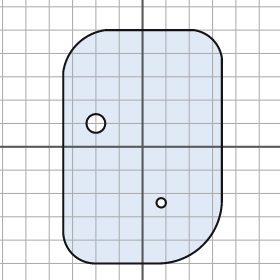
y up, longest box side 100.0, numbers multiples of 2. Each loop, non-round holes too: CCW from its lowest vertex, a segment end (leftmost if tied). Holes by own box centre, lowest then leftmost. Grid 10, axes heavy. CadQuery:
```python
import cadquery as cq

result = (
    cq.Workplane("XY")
    .moveTo(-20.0, -50.0)
    .lineTo(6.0, -50.0)
    .threePointArc((26.0, -42.0), (34.0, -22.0))
    .lineTo(34.0, 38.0)
    .threePointArc((30.0, 46.0), (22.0, 50.0))
    .lineTo(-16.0, 50.0)
    .threePointArc((-28.0, 44.0), (-34.0, 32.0))
    .lineTo(-34.0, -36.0)
    .threePointArc((-30.0, -46.0), (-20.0, -50.0))
    .close()
    .moveTo(8.0, -24.0)
    .circle(2.0)
    .moveTo(-20.0, 10.0)
    .circle(4.0)
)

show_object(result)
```